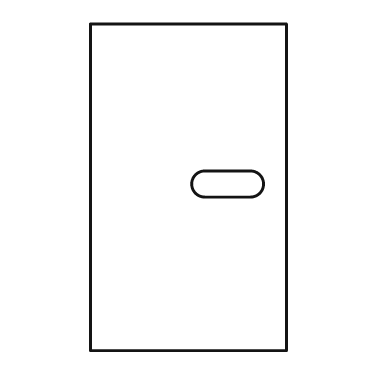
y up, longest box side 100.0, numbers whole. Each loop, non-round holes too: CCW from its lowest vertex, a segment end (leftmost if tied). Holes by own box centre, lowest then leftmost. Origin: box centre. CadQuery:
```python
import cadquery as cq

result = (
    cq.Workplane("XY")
    .moveTo(-30.0, -50.0)
    .lineTo(30.0, -50.0)
    .lineTo(30.0, 50.0)
    .lineTo(-30.0, 50.0)
    .close()
    .moveTo(5.0, -3.0)
    .lineTo(19.0, -3.0)
    .threePointArc((23.0, 1.0), (19.0, 5.0))
    .lineTo(5.0, 5.0)
    .threePointArc((1.0, 1.0), (5.0, -3.0))
    .close()
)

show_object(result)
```